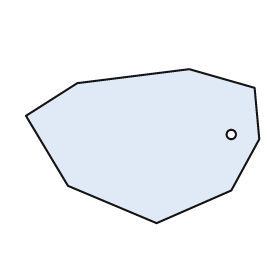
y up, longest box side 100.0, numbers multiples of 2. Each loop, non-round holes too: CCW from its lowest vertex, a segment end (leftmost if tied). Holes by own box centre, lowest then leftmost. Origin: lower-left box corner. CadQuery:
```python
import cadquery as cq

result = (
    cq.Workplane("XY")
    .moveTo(56.0, 0.0)
    .lineTo(88.0, 14.0)
    .lineTo(100.0, 36.0)
    .lineTo(98.0, 58.0)
    .lineTo(70.0, 66.0)
    .lineTo(22.0, 60.0)
    .lineTo(0.0, 46.0)
    .lineTo(18.0, 16.0)
    .close()
    .moveTo(88.0, 38.0)
    .circle(2.0)
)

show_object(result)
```